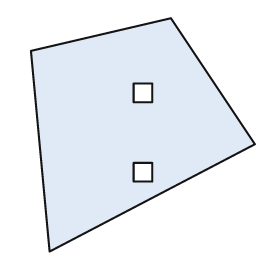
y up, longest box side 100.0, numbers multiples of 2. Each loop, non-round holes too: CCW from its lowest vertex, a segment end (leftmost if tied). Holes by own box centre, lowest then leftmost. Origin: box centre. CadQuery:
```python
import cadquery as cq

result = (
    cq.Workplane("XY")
    .moveTo(-40.0, -50.0)
    .lineTo(48.0, -4.0)
    .lineTo(12.0, 50.0)
    .lineTo(-48.0, 36.0)
    .close()
    .moveTo(-4.0, -20.0)
    .lineTo(4.0, -20.0)
    .lineTo(4.0, -12.0)
    .lineTo(-4.0, -12.0)
    .close()
    .moveTo(-4.0, 14.0)
    .lineTo(4.0, 14.0)
    .lineTo(4.0, 22.0)
    .lineTo(-4.0, 22.0)
    .close()
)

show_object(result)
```